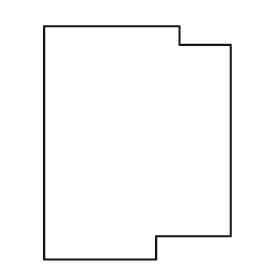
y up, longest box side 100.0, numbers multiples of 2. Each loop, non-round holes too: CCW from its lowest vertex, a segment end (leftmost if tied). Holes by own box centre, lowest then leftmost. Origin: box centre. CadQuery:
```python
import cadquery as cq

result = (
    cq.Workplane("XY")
    .moveTo(-40.0, -50.0)
    .lineTo(8.0, -50.0)
    .lineTo(8.0, -40.0)
    .lineTo(40.0, -40.0)
    .lineTo(40.0, 42.0)
    .lineTo(18.0, 42.0)
    .lineTo(18.0, 50.0)
    .lineTo(-40.0, 50.0)
    .close()
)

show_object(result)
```